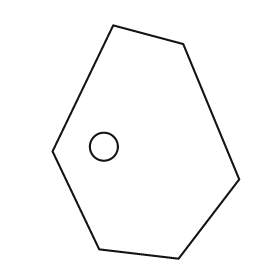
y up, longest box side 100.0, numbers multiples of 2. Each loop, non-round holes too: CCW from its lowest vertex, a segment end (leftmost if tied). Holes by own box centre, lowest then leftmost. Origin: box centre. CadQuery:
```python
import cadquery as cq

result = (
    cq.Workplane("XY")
    .moveTo(14.0, -50.0)
    .lineTo(40.0, -16.0)
    .lineTo(16.0, 42.0)
    .lineTo(-14.0, 50.0)
    .lineTo(-40.0, -4.0)
    .lineTo(-20.0, -46.0)
    .close()
    .moveTo(-18.0, -2.0)
    .circle(6.0)
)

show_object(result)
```